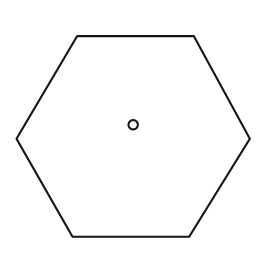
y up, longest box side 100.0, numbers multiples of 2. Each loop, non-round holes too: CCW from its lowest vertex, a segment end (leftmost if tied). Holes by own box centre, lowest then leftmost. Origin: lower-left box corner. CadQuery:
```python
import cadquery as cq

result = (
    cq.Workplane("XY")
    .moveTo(24.0, 0.0)
    .lineTo(74.0, 0.0)
    .lineTo(100.0, 42.0)
    .lineTo(76.0, 86.0)
    .lineTo(26.0, 86.0)
    .lineTo(0.0, 42.0)
    .close()
    .moveTo(50.0, 48.0)
    .circle(2.0)
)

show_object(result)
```